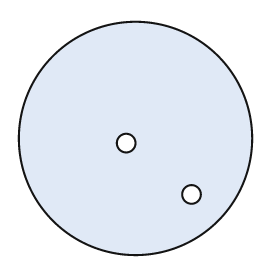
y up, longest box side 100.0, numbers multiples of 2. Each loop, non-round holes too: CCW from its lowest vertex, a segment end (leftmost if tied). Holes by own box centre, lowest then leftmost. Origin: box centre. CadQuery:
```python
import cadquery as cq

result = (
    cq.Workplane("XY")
    .moveTo(0.0, 0.0)
    .circle(50.0)
    .moveTo(24.0, -24.0)
    .circle(4.0)
    .moveTo(-4.0, -2.0)
    .circle(4.0)
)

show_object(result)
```